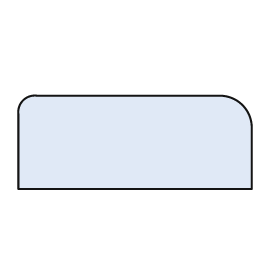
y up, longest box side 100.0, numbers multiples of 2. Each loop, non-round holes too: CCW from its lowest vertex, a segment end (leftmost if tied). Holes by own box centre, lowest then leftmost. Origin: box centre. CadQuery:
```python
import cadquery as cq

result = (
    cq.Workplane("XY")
    .moveTo(-50.0, -20.0)
    .lineTo(50.0, -20.0)
    .lineTo(50.0, 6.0)
    .threePointArc((46.0, 16.0), (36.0, 20.0))
    .lineTo(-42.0, 20.0)
    .threePointArc((-48.0, 18.0), (-50.0, 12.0))
    .close()
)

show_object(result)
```